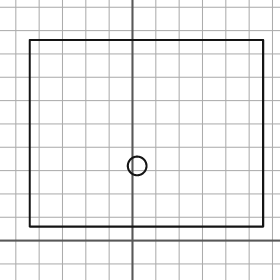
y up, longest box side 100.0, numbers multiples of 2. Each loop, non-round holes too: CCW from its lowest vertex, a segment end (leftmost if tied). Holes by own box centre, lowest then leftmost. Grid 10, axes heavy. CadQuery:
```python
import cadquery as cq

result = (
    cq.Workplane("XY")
    .moveTo(-44.0, 6.0)
    .lineTo(56.0, 6.0)
    .lineTo(56.0, 86.0)
    .lineTo(-44.0, 86.0)
    .close()
    .moveTo(2.0, 32.0)
    .circle(4.0)
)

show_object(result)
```